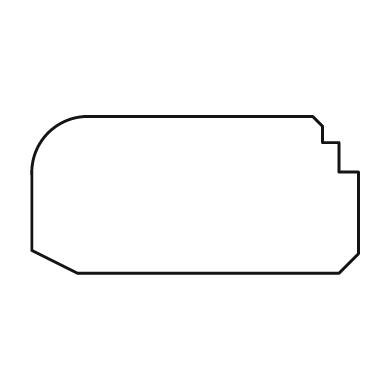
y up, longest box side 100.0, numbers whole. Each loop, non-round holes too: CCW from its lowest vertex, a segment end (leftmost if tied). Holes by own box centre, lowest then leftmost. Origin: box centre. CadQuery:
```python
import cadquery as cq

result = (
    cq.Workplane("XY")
    .moveTo(-36.0, -24.0)
    .lineTo(44.0, -24.0)
    .lineTo(50.0, -18.0)
    .lineTo(50.0, 7.0)
    .lineTo(44.0, 7.0)
    .lineTo(44.0, 16.0)
    .lineTo(39.0, 16.0)
    .lineTo(39.0, 21.0)
    .lineTo(36.0, 24.0)
    .lineTo(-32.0, 24.0)
    .threePointArc((-45.0, 19.0), (-50.0, 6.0))
    .lineTo(-50.0, -17.0)
    .close()
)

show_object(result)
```